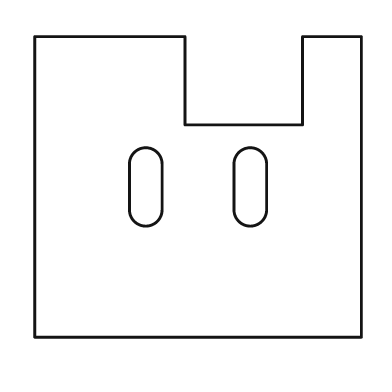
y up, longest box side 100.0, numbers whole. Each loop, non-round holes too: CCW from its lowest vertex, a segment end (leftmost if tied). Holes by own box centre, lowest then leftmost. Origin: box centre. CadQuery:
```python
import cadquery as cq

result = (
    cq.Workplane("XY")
    .moveTo(-50.0, -46.0)
    .lineTo(50.0, -46.0)
    .lineTo(50.0, 46.0)
    .lineTo(32.0, 46.0)
    .lineTo(32.0, 19.0)
    .lineTo(-4.0, 19.0)
    .lineTo(-4.0, 46.0)
    .lineTo(-50.0, 46.0)
    .close()
    .moveTo(-21.0, -7.0)
    .threePointArc((-16.0, -12.0), (-11.0, -7.0))
    .lineTo(-11.0, 7.0)
    .threePointArc((-16.0, 12.0), (-21.0, 7.0))
    .close()
    .moveTo(11.0, -7.0)
    .threePointArc((16.0, -12.0), (21.0, -7.0))
    .lineTo(21.0, 7.0)
    .threePointArc((16.0, 12.0), (11.0, 7.0))
    .close()
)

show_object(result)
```